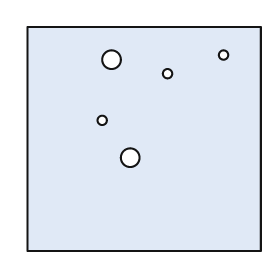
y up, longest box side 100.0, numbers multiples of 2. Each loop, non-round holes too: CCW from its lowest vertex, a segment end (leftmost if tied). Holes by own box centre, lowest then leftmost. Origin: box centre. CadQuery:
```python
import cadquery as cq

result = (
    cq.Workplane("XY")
    .moveTo(-50.0, -48.0)
    .lineTo(50.0, -48.0)
    .lineTo(50.0, 48.0)
    .lineTo(-50.0, 48.0)
    .close()
    .moveTo(-6.0, -8.0)
    .circle(4.0)
    .moveTo(-18.0, 8.0)
    .circle(2.0)
    .moveTo(10.0, 28.0)
    .circle(2.0)
    .moveTo(-14.0, 34.0)
    .circle(4.0)
    .moveTo(34.0, 36.0)
    .circle(2.0)
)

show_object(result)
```